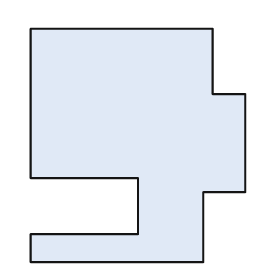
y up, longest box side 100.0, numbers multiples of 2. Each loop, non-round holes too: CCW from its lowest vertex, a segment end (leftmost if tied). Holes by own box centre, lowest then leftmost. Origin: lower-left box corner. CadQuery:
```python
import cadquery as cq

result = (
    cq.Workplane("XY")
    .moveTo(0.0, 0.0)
    .lineTo(74.0, 0.0)
    .lineTo(74.0, 30.0)
    .lineTo(92.0, 30.0)
    .lineTo(92.0, 72.0)
    .lineTo(78.0, 72.0)
    .lineTo(78.0, 100.0)
    .lineTo(0.0, 100.0)
    .lineTo(0.0, 36.0)
    .lineTo(46.0, 36.0)
    .lineTo(46.0, 12.0)
    .lineTo(0.0, 12.0)
    .close()
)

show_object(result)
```